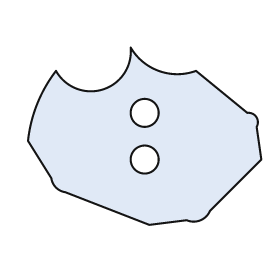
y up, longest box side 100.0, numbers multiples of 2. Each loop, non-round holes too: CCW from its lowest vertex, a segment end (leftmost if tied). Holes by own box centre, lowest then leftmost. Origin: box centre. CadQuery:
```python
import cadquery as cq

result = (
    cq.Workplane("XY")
    .moveTo(2.0, -38.0)
    .lineTo(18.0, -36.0)
    .threePointArc((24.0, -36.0), (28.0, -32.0))
    .lineTo(50.0, -10.0)
    .lineTo(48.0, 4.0)
    .threePointArc((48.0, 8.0), (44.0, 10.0))
    .lineTo(22.0, 28.0)
    .threePointArc((6.0, 28.0), (-6.0, 38.0))
    .threePointArc((-18.0, 20.0), (-38.0, 28.0))
    .threePointArc((-46.0, 14.0), (-50.0, -2.0))
    .lineTo(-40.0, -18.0)
    .threePointArc((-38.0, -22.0), (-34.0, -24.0))
    .close()
    .moveTo(0.0, -10.0)
    .circle(6.0)
    .moveTo(0.0, 10.0)
    .circle(6.0)
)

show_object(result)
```